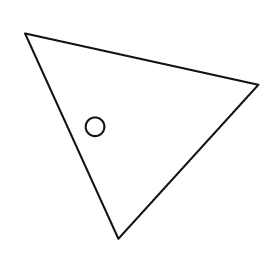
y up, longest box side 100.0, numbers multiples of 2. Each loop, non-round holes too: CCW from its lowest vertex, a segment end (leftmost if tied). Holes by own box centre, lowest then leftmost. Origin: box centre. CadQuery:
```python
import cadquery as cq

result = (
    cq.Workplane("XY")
    .moveTo(-10.0, -44.0)
    .lineTo(50.0, 22.0)
    .lineTo(-50.0, 44.0)
    .close()
    .moveTo(-20.0, 4.0)
    .circle(4.0)
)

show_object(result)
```